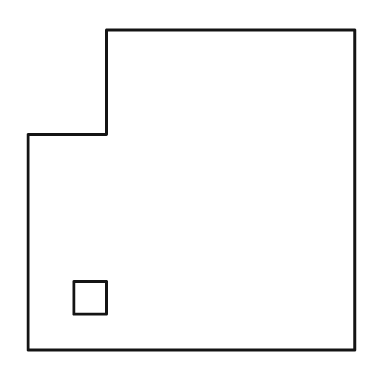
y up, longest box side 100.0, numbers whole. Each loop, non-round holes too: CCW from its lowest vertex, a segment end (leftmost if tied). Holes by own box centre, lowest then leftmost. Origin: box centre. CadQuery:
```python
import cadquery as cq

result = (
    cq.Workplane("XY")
    .moveTo(-50.0, -49.0)
    .lineTo(50.0, -49.0)
    .lineTo(50.0, 49.0)
    .lineTo(-26.0, 49.0)
    .lineTo(-26.0, 17.0)
    .lineTo(-50.0, 17.0)
    .close()
    .moveTo(-36.0, -38.0)
    .lineTo(-26.0, -38.0)
    .lineTo(-26.0, -28.0)
    .lineTo(-36.0, -28.0)
    .close()
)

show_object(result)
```